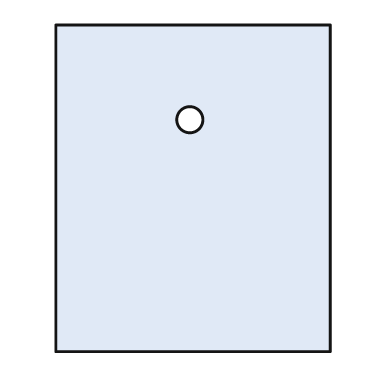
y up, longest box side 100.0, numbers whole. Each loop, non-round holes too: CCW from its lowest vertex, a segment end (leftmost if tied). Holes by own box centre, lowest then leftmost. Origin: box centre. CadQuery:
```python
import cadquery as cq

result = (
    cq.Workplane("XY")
    .moveTo(-42.0, -50.0)
    .lineTo(42.0, -50.0)
    .lineTo(42.0, 50.0)
    .lineTo(-42.0, 50.0)
    .close()
    .moveTo(-1.0, 21.0)
    .circle(4.0)
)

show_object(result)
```